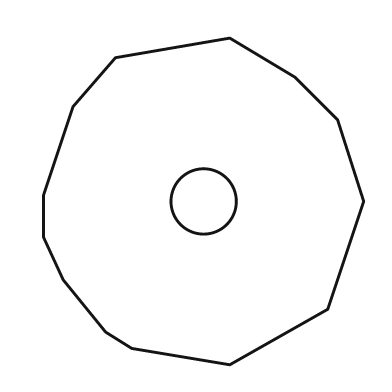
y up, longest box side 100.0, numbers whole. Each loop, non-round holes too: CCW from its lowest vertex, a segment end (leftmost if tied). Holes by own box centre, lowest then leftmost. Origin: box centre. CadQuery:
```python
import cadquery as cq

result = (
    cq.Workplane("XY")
    .moveTo(8.0, -50.0)
    .lineTo(38.0, -33.0)
    .lineTo(49.0, 0.0)
    .lineTo(41.0, 25.0)
    .lineTo(28.0, 38.0)
    .lineTo(8.0, 50.0)
    .lineTo(-27.0, 44.0)
    .lineTo(-40.0, 29.0)
    .lineTo(-49.0, 2.0)
    .lineTo(-49.0, -11.0)
    .lineTo(-43.0, -24.0)
    .lineTo(-30.0, -40.0)
    .lineTo(-22.0, -45.0)
    .close()
    .moveTo(0.0, 0.0)
    .circle(10.0)
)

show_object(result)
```